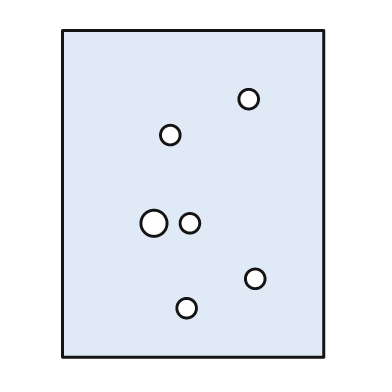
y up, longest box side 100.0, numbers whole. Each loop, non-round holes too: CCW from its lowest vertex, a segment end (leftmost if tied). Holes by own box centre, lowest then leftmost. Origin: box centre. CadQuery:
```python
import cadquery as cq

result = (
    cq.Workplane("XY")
    .moveTo(-40.0, -50.0)
    .lineTo(40.0, -50.0)
    .lineTo(40.0, 50.0)
    .lineTo(-40.0, 50.0)
    .close()
    .moveTo(-2.0, -35.0)
    .circle(3.0)
    .moveTo(19.0, -26.0)
    .circle(3.0)
    .moveTo(-12.0, -9.0)
    .circle(4.0)
    .moveTo(-1.0, -9.0)
    .circle(3.0)
    .moveTo(-7.0, 18.0)
    .circle(3.0)
    .moveTo(17.0, 29.0)
    .circle(3.0)
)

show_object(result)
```